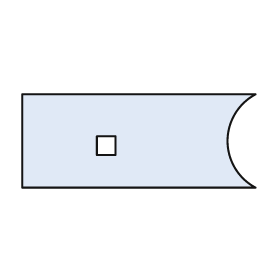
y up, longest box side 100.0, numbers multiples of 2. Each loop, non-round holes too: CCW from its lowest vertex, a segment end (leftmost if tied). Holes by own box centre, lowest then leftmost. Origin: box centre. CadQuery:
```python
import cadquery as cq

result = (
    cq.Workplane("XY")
    .moveTo(-50.0, -20.0)
    .lineTo(50.0, -20.0)
    .threePointArc((38.0, 0.0), (50.0, 20.0))
    .lineTo(-50.0, 20.0)
    .close()
    .moveTo(-18.0, -6.0)
    .lineTo(-10.0, -6.0)
    .lineTo(-10.0, 2.0)
    .lineTo(-18.0, 2.0)
    .close()
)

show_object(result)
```